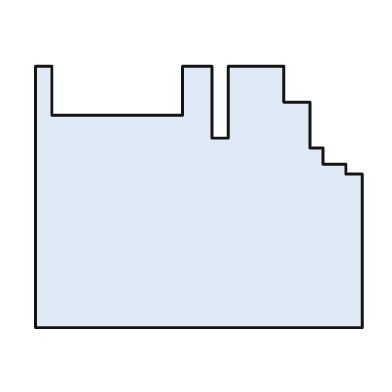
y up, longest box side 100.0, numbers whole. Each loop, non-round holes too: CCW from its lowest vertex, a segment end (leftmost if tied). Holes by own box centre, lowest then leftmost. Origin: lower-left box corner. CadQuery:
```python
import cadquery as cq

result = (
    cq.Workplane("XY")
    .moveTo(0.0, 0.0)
    .lineTo(100.0, 0.0)
    .lineTo(100.0, 47.0)
    .lineTo(95.0, 47.0)
    .lineTo(95.0, 50.0)
    .lineTo(88.0, 50.0)
    .lineTo(88.0, 55.0)
    .lineTo(84.0, 55.0)
    .lineTo(84.0, 69.0)
    .lineTo(76.0, 69.0)
    .lineTo(76.0, 80.0)
    .lineTo(59.0, 80.0)
    .lineTo(59.0, 58.0)
    .lineTo(54.0, 58.0)
    .lineTo(54.0, 80.0)
    .lineTo(45.0, 80.0)
    .lineTo(45.0, 65.0)
    .lineTo(5.0, 65.0)
    .lineTo(5.0, 80.0)
    .lineTo(0.0, 80.0)
    .close()
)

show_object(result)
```